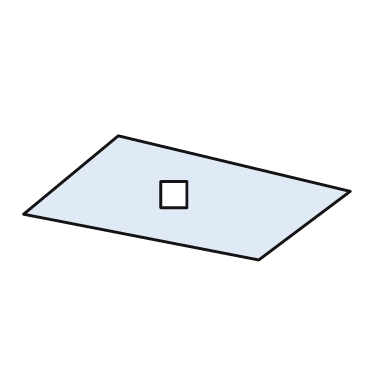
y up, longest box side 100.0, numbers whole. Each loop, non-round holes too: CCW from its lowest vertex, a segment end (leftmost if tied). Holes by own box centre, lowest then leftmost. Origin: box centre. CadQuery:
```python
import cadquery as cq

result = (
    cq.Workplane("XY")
    .moveTo(22.0, -19.0)
    .lineTo(50.0, 2.0)
    .lineTo(-21.0, 19.0)
    .lineTo(-50.0, -5.0)
    .close()
    .moveTo(-8.0, -3.0)
    .lineTo(0.0, -3.0)
    .lineTo(0.0, 5.0)
    .lineTo(-8.0, 5.0)
    .close()
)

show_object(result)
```